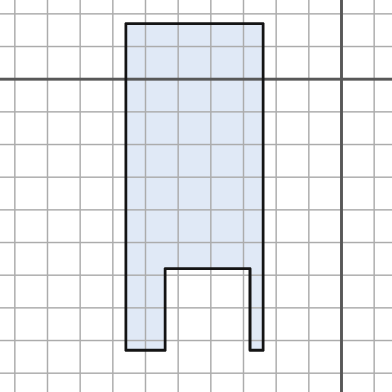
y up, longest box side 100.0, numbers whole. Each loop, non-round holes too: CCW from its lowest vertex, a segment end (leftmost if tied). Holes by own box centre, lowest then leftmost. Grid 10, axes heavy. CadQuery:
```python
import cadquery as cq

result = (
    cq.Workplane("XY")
    .moveTo(-66.0, -83.0)
    .lineTo(-54.0, -83.0)
    .lineTo(-54.0, -58.0)
    .lineTo(-28.0, -58.0)
    .lineTo(-28.0, -83.0)
    .lineTo(-24.0, -83.0)
    .lineTo(-24.0, 17.0)
    .lineTo(-66.0, 17.0)
    .close()
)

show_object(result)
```